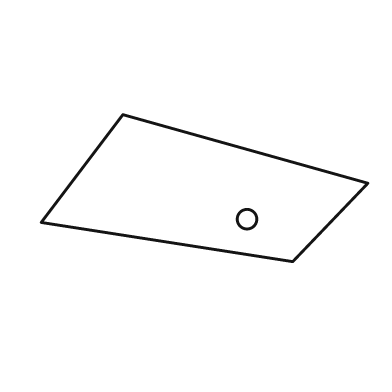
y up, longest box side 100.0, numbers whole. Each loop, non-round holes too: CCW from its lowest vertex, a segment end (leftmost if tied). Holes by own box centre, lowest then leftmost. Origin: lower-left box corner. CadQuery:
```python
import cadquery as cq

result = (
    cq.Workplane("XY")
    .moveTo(77.0, 0.0)
    .lineTo(100.0, 24.0)
    .lineTo(25.0, 45.0)
    .lineTo(0.0, 12.0)
    .close()
    .moveTo(63.0, 13.0)
    .circle(3.0)
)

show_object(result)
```